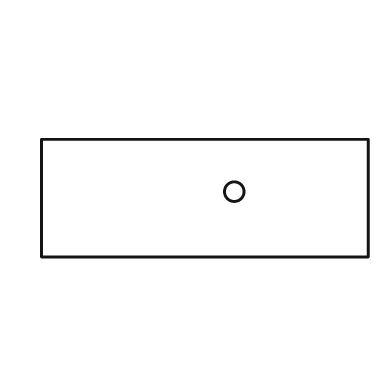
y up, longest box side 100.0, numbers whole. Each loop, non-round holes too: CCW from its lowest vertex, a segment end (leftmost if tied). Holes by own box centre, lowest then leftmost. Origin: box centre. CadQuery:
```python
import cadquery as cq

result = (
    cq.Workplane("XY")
    .moveTo(-50.0, -18.0)
    .lineTo(50.0, -18.0)
    .lineTo(50.0, 18.0)
    .lineTo(-50.0, 18.0)
    .close()
    .moveTo(9.0, 2.0)
    .circle(3.0)
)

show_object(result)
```